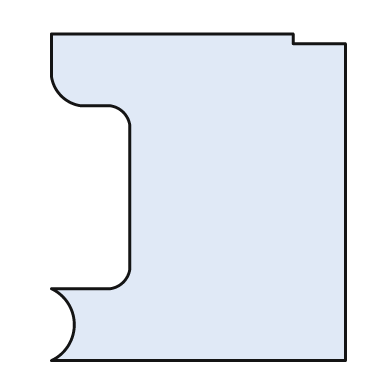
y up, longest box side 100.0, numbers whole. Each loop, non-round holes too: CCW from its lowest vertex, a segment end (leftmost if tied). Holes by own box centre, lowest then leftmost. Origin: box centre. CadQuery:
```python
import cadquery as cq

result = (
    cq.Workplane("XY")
    .moveTo(-45.0, -50.0)
    .lineTo(45.0, -50.0)
    .lineTo(45.0, 47.0)
    .lineTo(29.0, 47.0)
    .lineTo(29.0, 50.0)
    .lineTo(-45.0, 50.0)
    .lineTo(-45.0, 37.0)
    .threePointArc((-42.0, 31.0), (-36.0, 28.0))
    .lineTo(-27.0, 28.0)
    .threePointArc((-23.0, 26.0), (-21.0, 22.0))
    .lineTo(-21.0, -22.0)
    .threePointArc((-23.0, -26.0), (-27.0, -28.0))
    .lineTo(-45.0, -28.0)
    .threePointArc((-38.0, -39.0), (-45.0, -50.0))
    .close()
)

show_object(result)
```